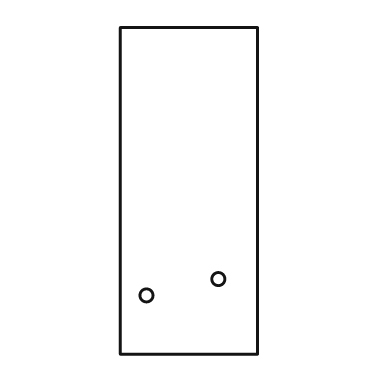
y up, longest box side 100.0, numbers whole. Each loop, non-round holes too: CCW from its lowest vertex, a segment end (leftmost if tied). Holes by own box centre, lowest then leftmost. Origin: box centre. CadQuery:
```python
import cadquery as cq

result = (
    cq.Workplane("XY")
    .moveTo(-21.0, -50.0)
    .lineTo(21.0, -50.0)
    .lineTo(21.0, 50.0)
    .lineTo(-21.0, 50.0)
    .close()
    .moveTo(-13.0, -32.0)
    .circle(2.0)
    .moveTo(9.0, -27.0)
    .circle(2.0)
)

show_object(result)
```